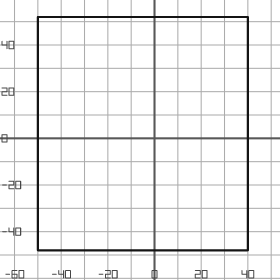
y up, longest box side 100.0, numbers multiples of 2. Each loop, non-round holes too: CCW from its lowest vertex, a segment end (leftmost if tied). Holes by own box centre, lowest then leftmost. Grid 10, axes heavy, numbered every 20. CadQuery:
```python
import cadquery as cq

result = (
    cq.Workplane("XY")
    .moveTo(-50.0, -48.0)
    .lineTo(40.0, -48.0)
    .lineTo(40.0, 52.0)
    .lineTo(-50.0, 52.0)
    .close()
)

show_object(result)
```